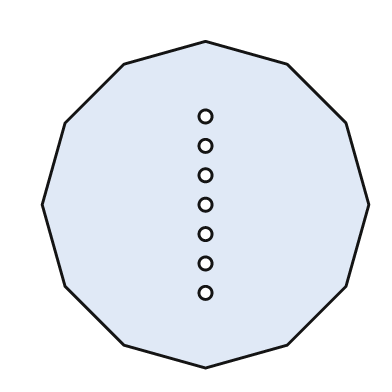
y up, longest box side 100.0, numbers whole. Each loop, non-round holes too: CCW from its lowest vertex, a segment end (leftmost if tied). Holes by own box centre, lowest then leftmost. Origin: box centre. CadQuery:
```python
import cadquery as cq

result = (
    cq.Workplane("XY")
    .moveTo(0.0, -50.0)
    .lineTo(25.0, -43.0)
    .lineTo(43.0, -25.0)
    .lineTo(50.0, 0.0)
    .lineTo(43.0, 25.0)
    .lineTo(25.0, 43.0)
    .lineTo(0.0, 50.0)
    .lineTo(-25.0, 43.0)
    .lineTo(-43.0, 25.0)
    .lineTo(-50.0, 0.0)
    .lineTo(-43.0, -25.0)
    .lineTo(-25.0, -43.0)
    .close()
    .moveTo(0.0, -27.0)
    .circle(2.0)
    .moveTo(0.0, -18.0)
    .circle(2.0)
    .moveTo(0.0, -9.0)
    .circle(2.0)
    .moveTo(0.0, 0.0)
    .circle(2.0)
    .moveTo(0.0, 9.0)
    .circle(2.0)
    .moveTo(0.0, 18.0)
    .circle(2.0)
    .moveTo(0.0, 27.0)
    .circle(2.0)
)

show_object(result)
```